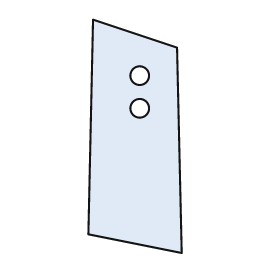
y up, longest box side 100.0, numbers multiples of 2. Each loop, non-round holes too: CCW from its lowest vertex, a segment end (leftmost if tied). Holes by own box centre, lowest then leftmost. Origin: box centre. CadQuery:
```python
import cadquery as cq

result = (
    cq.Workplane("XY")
    .moveTo(20.0, -50.0)
    .lineTo(18.0, 38.0)
    .lineTo(-18.0, 50.0)
    .lineTo(-20.0, -42.0)
    .close()
    .moveTo(2.0, 12.0)
    .circle(4.0)
    .moveTo(2.0, 26.0)
    .circle(4.0)
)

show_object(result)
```